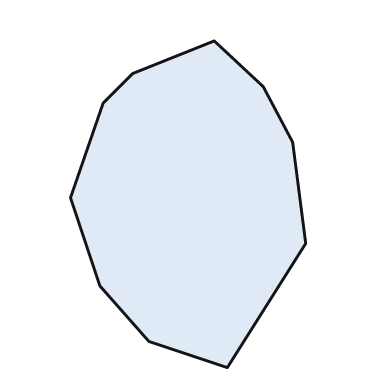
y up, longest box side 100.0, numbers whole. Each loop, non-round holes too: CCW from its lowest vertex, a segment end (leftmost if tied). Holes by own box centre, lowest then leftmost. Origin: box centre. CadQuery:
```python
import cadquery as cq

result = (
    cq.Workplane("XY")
    .moveTo(12.0, -50.0)
    .lineTo(36.0, -12.0)
    .lineTo(32.0, 19.0)
    .lineTo(23.0, 36.0)
    .lineTo(8.0, 50.0)
    .lineTo(-17.0, 40.0)
    .lineTo(-26.0, 31.0)
    .lineTo(-36.0, 2.0)
    .lineTo(-27.0, -25.0)
    .lineTo(-12.0, -42.0)
    .close()
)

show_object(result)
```